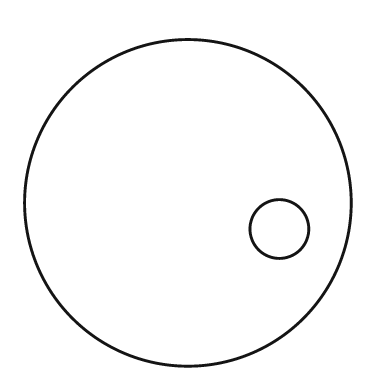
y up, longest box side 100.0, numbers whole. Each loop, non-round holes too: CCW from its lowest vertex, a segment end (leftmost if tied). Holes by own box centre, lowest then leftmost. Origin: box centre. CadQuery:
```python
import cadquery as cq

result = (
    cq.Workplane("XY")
    .moveTo(0.0, 0.0)
    .circle(50.0)
    .moveTo(28.0, -8.0)
    .circle(9.0)
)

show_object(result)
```